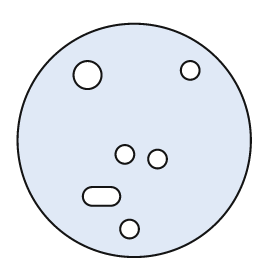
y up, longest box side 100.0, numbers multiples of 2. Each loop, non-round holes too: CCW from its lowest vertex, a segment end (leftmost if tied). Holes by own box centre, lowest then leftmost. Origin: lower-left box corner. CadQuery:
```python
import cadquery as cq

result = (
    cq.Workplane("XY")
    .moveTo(50.0, 50.0)
    .circle(50.0)
    .moveTo(48.0, 12.0)
    .circle(4.0)
    .moveTo(32.0, 22.0)
    .lineTo(40.0, 22.0)
    .threePointArc((44.0, 26.0), (40.0, 30.0))
    .lineTo(32.0, 30.0)
    .threePointArc((28.0, 26.0), (32.0, 22.0))
    .close()
    .moveTo(60.0, 42.0)
    .circle(4.0)
    .moveTo(46.0, 44.0)
    .circle(4.0)
    .moveTo(30.0, 78.0)
    .circle(6.0)
    .moveTo(74.0, 80.0)
    .circle(4.0)
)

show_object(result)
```